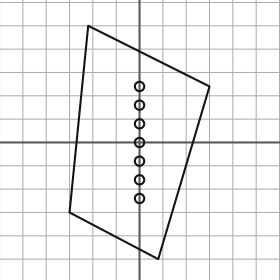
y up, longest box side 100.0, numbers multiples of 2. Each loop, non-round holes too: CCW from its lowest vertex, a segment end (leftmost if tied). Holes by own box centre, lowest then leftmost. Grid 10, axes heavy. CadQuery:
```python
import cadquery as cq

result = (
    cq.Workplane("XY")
    .moveTo(8.0, -50.0)
    .lineTo(30.0, 24.0)
    .lineTo(-22.0, 50.0)
    .lineTo(-30.0, -30.0)
    .close()
    .moveTo(0.0, -24.0)
    .circle(2.0)
    .moveTo(0.0, -16.0)
    .circle(2.0)
    .moveTo(0.0, -8.0)
    .circle(2.0)
    .moveTo(0.0, 0.0)
    .circle(2.0)
    .moveTo(0.0, 8.0)
    .circle(2.0)
    .moveTo(0.0, 16.0)
    .circle(2.0)
    .moveTo(0.0, 24.0)
    .circle(2.0)
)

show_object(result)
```